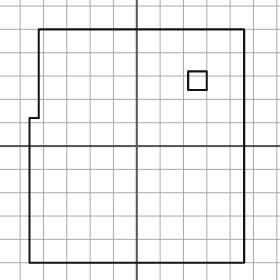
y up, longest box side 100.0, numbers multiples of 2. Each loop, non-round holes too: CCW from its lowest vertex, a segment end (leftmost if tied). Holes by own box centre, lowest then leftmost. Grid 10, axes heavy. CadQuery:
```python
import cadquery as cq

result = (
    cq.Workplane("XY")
    .moveTo(-46.0, -50.0)
    .lineTo(46.0, -50.0)
    .lineTo(46.0, 50.0)
    .lineTo(-42.0, 50.0)
    .lineTo(-42.0, 12.0)
    .lineTo(-46.0, 12.0)
    .close()
    .moveTo(22.0, 24.0)
    .lineTo(30.0, 24.0)
    .lineTo(30.0, 32.0)
    .lineTo(22.0, 32.0)
    .close()
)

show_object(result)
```